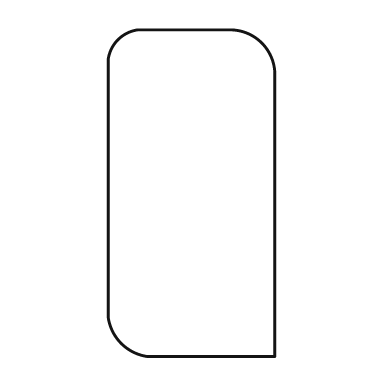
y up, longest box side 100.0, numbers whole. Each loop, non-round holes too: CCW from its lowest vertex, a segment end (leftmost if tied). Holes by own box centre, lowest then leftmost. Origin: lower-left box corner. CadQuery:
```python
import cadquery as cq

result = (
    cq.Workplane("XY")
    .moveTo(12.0, 0.0)
    .lineTo(51.0, 0.0)
    .lineTo(51.0, 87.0)
    .threePointArc((47.0, 96.0), (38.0, 100.0))
    .lineTo(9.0, 100.0)
    .threePointArc((3.0, 97.0), (0.0, 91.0))
    .lineTo(0.0, 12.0)
    .threePointArc((4.0, 4.0), (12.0, 0.0))
    .close()
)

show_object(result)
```